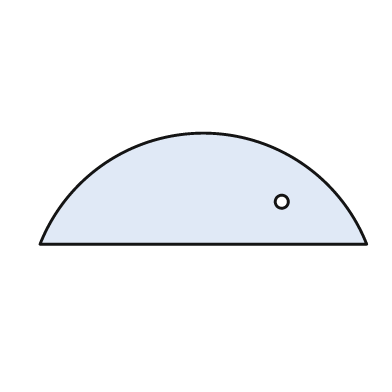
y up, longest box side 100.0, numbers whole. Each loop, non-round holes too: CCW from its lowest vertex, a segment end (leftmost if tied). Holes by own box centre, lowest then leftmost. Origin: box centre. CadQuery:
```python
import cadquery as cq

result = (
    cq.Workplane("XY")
    .moveTo(-50.0, -17.0)
    .lineTo(50.0, -17.0)
    .threePointArc((0.0, 17.0), (-50.0, -17.0))
    .close()
    .moveTo(24.0, -4.0)
    .circle(2.0)
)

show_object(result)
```